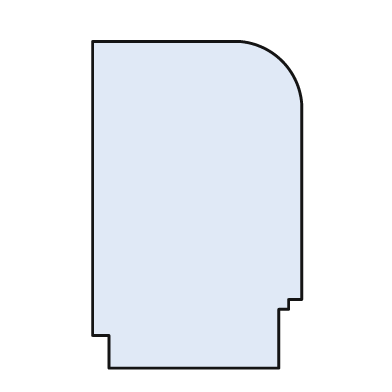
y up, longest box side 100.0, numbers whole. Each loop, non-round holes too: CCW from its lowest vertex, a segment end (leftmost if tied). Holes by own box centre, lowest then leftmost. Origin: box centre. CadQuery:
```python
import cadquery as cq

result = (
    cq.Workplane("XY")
    .moveTo(-27.0, -50.0)
    .lineTo(25.0, -50.0)
    .lineTo(25.0, -32.0)
    .lineTo(28.0, -32.0)
    .lineTo(28.0, -29.0)
    .lineTo(32.0, -29.0)
    .lineTo(32.0, 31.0)
    .threePointArc((26.0, 44.0), (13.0, 50.0))
    .lineTo(-32.0, 50.0)
    .lineTo(-32.0, -40.0)
    .lineTo(-27.0, -40.0)
    .close()
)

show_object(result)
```